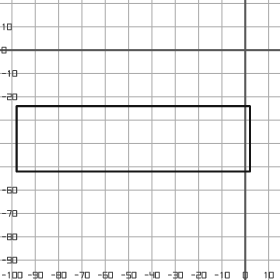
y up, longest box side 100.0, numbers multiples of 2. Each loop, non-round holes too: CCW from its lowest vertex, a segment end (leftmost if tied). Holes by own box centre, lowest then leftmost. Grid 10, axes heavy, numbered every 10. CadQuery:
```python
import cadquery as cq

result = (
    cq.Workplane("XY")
    .moveTo(-98.0, -52.0)
    .lineTo(2.0, -52.0)
    .lineTo(2.0, -24.0)
    .lineTo(-98.0, -24.0)
    .close()
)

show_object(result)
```